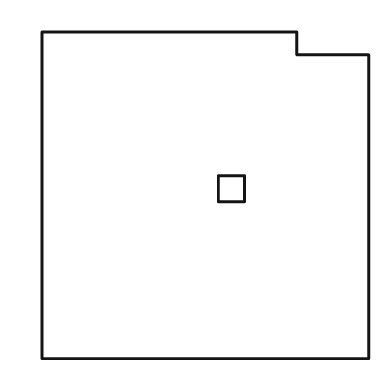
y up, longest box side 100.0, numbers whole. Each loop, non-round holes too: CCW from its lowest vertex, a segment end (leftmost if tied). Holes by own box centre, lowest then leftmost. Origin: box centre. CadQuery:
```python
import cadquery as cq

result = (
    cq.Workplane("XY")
    .moveTo(-50.0, -50.0)
    .lineTo(50.0, -50.0)
    .lineTo(50.0, 43.0)
    .lineTo(28.0, 43.0)
    .lineTo(28.0, 50.0)
    .lineTo(-50.0, 50.0)
    .close()
    .moveTo(4.0, -2.0)
    .lineTo(12.0, -2.0)
    .lineTo(12.0, 6.0)
    .lineTo(4.0, 6.0)
    .close()
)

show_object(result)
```